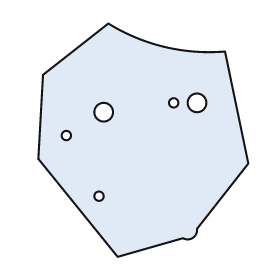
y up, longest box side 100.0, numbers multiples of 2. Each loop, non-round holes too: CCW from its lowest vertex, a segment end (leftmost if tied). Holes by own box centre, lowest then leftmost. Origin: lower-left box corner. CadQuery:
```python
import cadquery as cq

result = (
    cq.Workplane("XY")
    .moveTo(34.0, 0.0)
    .lineTo(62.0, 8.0)
    .threePointArc((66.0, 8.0), (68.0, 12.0))
    .lineTo(90.0, 40.0)
    .lineTo(80.0, 88.0)
    .threePointArc((54.0, 90.0), (30.0, 100.0))
    .lineTo(2.0, 78.0)
    .lineTo(0.0, 42.0)
    .close()
    .moveTo(26.0, 26.0)
    .circle(2.0)
    .moveTo(12.0, 52.0)
    .circle(2.0)
    .moveTo(28.0, 62.0)
    .circle(4.0)
    .moveTo(58.0, 66.0)
    .circle(2.0)
    .moveTo(68.0, 66.0)
    .circle(4.0)
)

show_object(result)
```